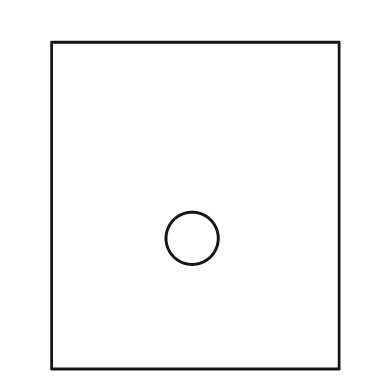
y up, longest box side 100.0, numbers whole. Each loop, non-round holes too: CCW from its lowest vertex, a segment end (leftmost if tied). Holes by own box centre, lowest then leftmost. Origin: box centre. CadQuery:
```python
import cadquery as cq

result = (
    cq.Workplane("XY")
    .moveTo(-44.0, -50.0)
    .lineTo(44.0, -50.0)
    .lineTo(44.0, 50.0)
    .lineTo(-44.0, 50.0)
    .close()
    .moveTo(-1.0, -10.0)
    .circle(8.0)
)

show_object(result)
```